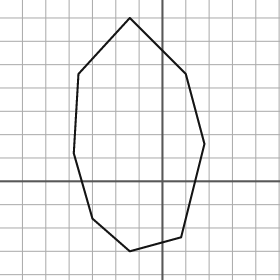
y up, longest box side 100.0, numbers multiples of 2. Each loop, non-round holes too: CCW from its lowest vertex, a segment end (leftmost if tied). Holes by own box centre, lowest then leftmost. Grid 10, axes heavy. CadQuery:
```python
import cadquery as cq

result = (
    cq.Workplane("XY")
    .moveTo(-14.0, -30.0)
    .lineTo(8.0, -24.0)
    .lineTo(18.0, 16.0)
    .lineTo(10.0, 46.0)
    .lineTo(-14.0, 70.0)
    .lineTo(-36.0, 46.0)
    .lineTo(-38.0, 12.0)
    .lineTo(-30.0, -16.0)
    .close()
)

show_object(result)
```